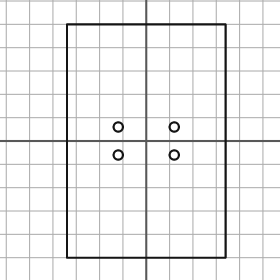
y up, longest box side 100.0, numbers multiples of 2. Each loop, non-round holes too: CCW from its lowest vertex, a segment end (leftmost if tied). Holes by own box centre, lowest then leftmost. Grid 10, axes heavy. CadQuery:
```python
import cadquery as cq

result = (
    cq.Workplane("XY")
    .moveTo(-34.0, -50.0)
    .lineTo(34.0, -50.0)
    .lineTo(34.0, 50.0)
    .lineTo(-34.0, 50.0)
    .close()
    .moveTo(-12.0, -6.0)
    .circle(2.0)
    .moveTo(12.0, -6.0)
    .circle(2.0)
    .moveTo(-12.0, 6.0)
    .circle(2.0)
    .moveTo(12.0, 6.0)
    .circle(2.0)
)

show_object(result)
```